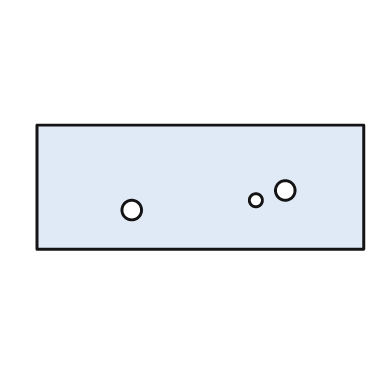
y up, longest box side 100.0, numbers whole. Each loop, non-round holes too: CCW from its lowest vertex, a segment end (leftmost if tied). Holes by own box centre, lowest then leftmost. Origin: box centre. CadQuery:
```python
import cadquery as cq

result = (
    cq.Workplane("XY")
    .moveTo(-50.0, -19.0)
    .lineTo(50.0, -19.0)
    .lineTo(50.0, 19.0)
    .lineTo(-50.0, 19.0)
    .close()
    .moveTo(-21.0, -7.0)
    .circle(3.0)
    .moveTo(17.0, -4.0)
    .circle(2.0)
    .moveTo(26.0, -1.0)
    .circle(3.0)
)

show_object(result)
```